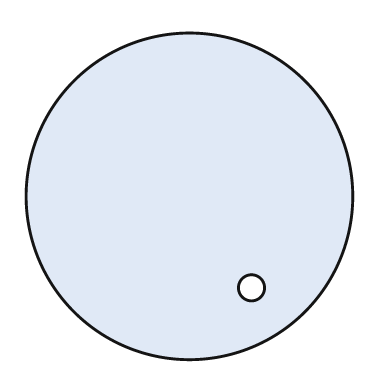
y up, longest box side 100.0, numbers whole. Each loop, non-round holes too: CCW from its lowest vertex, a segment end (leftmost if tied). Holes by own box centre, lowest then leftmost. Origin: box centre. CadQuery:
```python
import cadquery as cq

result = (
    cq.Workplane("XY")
    .moveTo(0.0, 0.0)
    .circle(50.0)
    .moveTo(19.0, -28.0)
    .circle(4.0)
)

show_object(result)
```